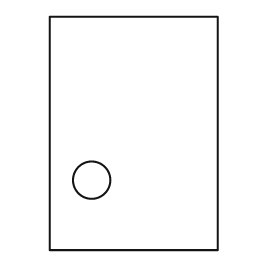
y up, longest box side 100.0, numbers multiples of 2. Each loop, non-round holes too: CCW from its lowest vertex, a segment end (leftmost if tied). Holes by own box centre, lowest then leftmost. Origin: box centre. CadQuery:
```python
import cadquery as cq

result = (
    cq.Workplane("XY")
    .moveTo(-36.0, -50.0)
    .lineTo(36.0, -50.0)
    .lineTo(36.0, 50.0)
    .lineTo(-36.0, 50.0)
    .close()
    .moveTo(-18.0, -20.0)
    .circle(8.0)
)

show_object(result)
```